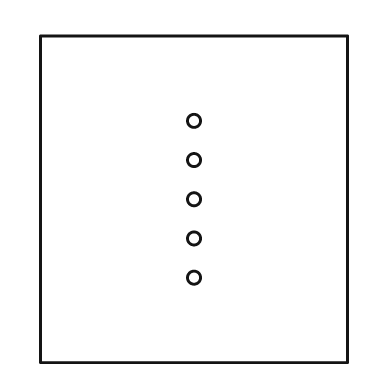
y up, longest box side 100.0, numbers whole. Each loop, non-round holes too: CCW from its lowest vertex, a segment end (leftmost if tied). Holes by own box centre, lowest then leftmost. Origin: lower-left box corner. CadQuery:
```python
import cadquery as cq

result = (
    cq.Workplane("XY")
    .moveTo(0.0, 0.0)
    .lineTo(94.0, 0.0)
    .lineTo(94.0, 100.0)
    .lineTo(0.0, 100.0)
    .close()
    .moveTo(47.0, 26.0)
    .circle(2.0)
    .moveTo(47.0, 38.0)
    .circle(2.0)
    .moveTo(47.0, 50.0)
    .circle(2.0)
    .moveTo(47.0, 62.0)
    .circle(2.0)
    .moveTo(47.0, 74.0)
    .circle(2.0)
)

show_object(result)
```